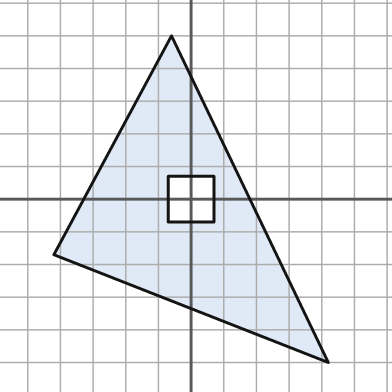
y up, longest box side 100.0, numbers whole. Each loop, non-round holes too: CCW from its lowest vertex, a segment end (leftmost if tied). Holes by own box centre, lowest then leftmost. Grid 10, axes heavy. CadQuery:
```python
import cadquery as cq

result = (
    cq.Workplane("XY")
    .moveTo(42.0, -50.0)
    .lineTo(-6.0, 50.0)
    .lineTo(-42.0, -17.0)
    .close()
    .moveTo(-7.0, -7.0)
    .lineTo(7.0, -7.0)
    .lineTo(7.0, 7.0)
    .lineTo(-7.0, 7.0)
    .close()
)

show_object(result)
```